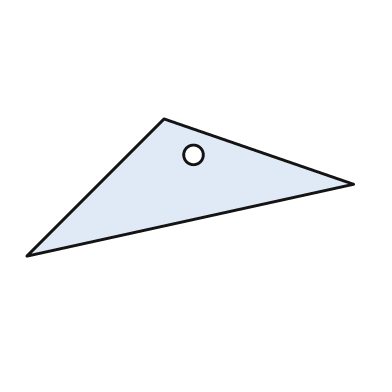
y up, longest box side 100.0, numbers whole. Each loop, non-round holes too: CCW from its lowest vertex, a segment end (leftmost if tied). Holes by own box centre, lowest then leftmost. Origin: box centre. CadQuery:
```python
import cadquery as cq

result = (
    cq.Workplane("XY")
    .moveTo(-50.0, -21.0)
    .lineTo(50.0, 1.0)
    .lineTo(-8.0, 21.0)
    .close()
    .moveTo(1.0, 10.0)
    .circle(3.0)
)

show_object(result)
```